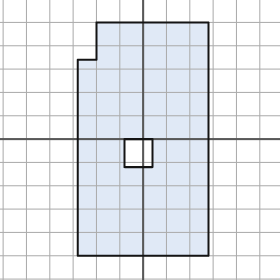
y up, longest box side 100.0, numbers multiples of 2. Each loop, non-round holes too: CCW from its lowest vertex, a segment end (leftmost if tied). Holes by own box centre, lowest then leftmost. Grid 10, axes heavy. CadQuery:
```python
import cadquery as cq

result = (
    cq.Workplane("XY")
    .moveTo(-28.0, -50.0)
    .lineTo(28.0, -50.0)
    .lineTo(28.0, 50.0)
    .lineTo(-20.0, 50.0)
    .lineTo(-20.0, 34.0)
    .lineTo(-28.0, 34.0)
    .close()
    .moveTo(-8.0, -12.0)
    .lineTo(4.0, -12.0)
    .lineTo(4.0, 0.0)
    .lineTo(-8.0, 0.0)
    .close()
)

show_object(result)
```